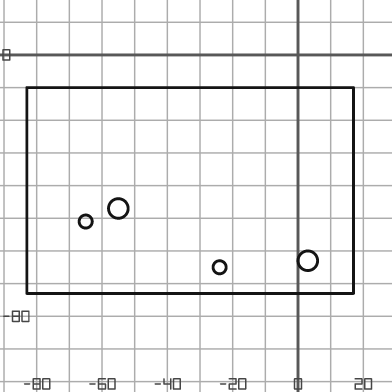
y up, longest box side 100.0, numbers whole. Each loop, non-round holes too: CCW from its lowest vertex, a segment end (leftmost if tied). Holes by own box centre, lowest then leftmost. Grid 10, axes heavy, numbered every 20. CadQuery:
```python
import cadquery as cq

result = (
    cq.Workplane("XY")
    .moveTo(-83.0, -73.0)
    .lineTo(17.0, -73.0)
    .lineTo(17.0, -10.0)
    .lineTo(-83.0, -10.0)
    .close()
    .moveTo(-24.0, -65.0)
    .circle(2.0)
    .moveTo(3.0, -63.0)
    .circle(3.0)
    .moveTo(-65.0, -51.0)
    .circle(2.0)
    .moveTo(-55.0, -47.0)
    .circle(3.0)
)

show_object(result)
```